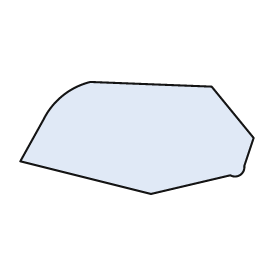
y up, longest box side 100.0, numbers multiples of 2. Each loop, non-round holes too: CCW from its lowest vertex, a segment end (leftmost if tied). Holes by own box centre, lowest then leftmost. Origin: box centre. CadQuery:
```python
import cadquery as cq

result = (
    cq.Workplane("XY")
    .moveTo(6.0, -24.0)
    .lineTo(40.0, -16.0)
    .threePointArc((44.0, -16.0), (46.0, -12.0))
    .lineTo(50.0, 0.0)
    .lineTo(32.0, 22.0)
    .lineTo(-20.0, 24.0)
    .threePointArc((-32.0, 18.0), (-40.0, 8.0))
    .lineTo(-50.0, -10.0)
    .close()
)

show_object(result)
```